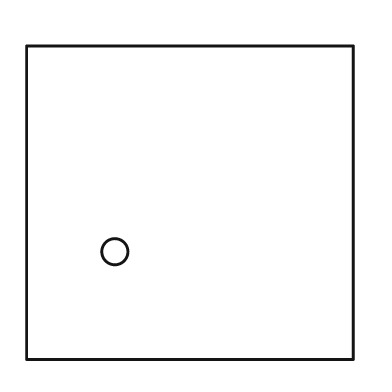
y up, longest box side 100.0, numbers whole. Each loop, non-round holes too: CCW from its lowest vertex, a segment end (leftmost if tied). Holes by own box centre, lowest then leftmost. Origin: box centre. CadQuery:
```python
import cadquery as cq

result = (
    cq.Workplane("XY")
    .moveTo(-50.0, -48.0)
    .lineTo(50.0, -48.0)
    .lineTo(50.0, 48.0)
    .lineTo(-50.0, 48.0)
    .close()
    .moveTo(-23.0, -15.0)
    .circle(4.0)
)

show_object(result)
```